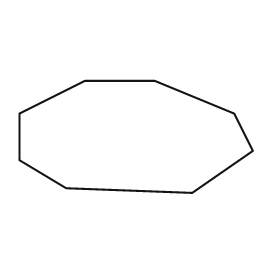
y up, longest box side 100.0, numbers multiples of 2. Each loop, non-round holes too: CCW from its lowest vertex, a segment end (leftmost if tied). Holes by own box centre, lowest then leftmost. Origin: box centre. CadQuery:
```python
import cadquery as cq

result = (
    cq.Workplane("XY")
    .moveTo(24.0, -24.0)
    .lineTo(50.0, -6.0)
    .lineTo(42.0, 10.0)
    .lineTo(8.0, 24.0)
    .lineTo(-22.0, 24.0)
    .lineTo(-50.0, 10.0)
    .lineTo(-50.0, -10.0)
    .lineTo(-30.0, -22.0)
    .close()
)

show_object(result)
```